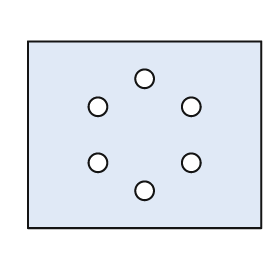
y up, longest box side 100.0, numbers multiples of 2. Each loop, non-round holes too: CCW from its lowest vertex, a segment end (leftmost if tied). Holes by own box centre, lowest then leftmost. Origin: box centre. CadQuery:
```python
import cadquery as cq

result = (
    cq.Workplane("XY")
    .moveTo(-50.0, -40.0)
    .lineTo(50.0, -40.0)
    .lineTo(50.0, 40.0)
    .lineTo(-50.0, 40.0)
    .close()
    .moveTo(0.0, -24.0)
    .circle(4.0)
    .moveTo(-20.0, -12.0)
    .circle(4.0)
    .moveTo(20.0, -12.0)
    .circle(4.0)
    .moveTo(-20.0, 12.0)
    .circle(4.0)
    .moveTo(20.0, 12.0)
    .circle(4.0)
    .moveTo(0.0, 24.0)
    .circle(4.0)
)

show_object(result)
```